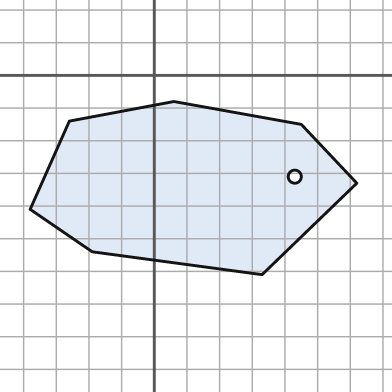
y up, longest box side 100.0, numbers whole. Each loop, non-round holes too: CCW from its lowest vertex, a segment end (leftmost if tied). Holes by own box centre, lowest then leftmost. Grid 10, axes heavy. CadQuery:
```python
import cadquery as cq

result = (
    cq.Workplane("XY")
    .moveTo(33.0, -61.0)
    .lineTo(62.0, -33.0)
    .lineTo(45.0, -15.0)
    .lineTo(6.0, -8.0)
    .lineTo(-26.0, -14.0)
    .lineTo(-38.0, -41.0)
    .lineTo(-19.0, -54.0)
    .close()
    .moveTo(43.0, -31.0)
    .circle(2.0)
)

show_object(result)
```